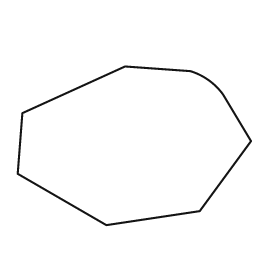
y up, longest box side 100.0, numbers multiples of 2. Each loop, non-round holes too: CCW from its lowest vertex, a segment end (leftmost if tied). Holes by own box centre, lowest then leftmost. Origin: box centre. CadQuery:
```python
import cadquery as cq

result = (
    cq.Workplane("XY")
    .moveTo(-12.0, -34.0)
    .lineTo(28.0, -28.0)
    .lineTo(50.0, 2.0)
    .lineTo(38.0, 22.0)
    .threePointArc((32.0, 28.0), (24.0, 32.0))
    .lineTo(-4.0, 34.0)
    .lineTo(-48.0, 14.0)
    .lineTo(-50.0, -12.0)
    .close()
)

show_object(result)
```